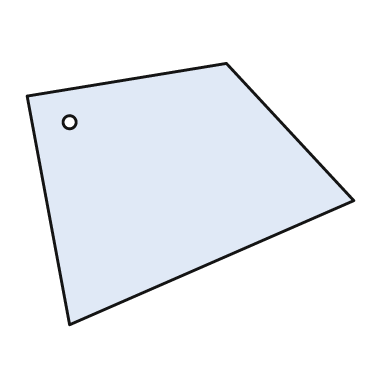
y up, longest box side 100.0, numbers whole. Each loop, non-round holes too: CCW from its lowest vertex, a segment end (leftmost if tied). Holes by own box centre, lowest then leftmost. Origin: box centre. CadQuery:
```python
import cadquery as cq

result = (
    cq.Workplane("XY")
    .moveTo(-37.0, -40.0)
    .lineTo(50.0, -2.0)
    .lineTo(11.0, 40.0)
    .lineTo(-50.0, 30.0)
    .close()
    .moveTo(-37.0, 22.0)
    .circle(2.0)
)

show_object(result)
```